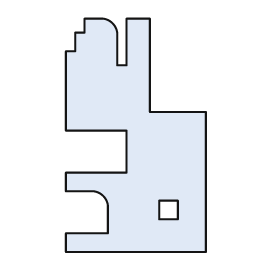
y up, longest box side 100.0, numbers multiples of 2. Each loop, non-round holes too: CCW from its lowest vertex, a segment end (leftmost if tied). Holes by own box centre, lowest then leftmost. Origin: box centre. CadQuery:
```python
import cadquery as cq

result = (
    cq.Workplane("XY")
    .moveTo(-30.0, -50.0)
    .lineTo(30.0, -50.0)
    .lineTo(30.0, 10.0)
    .lineTo(6.0, 10.0)
    .lineTo(6.0, 50.0)
    .lineTo(-4.0, 50.0)
    .lineTo(-4.0, 30.0)
    .lineTo(-8.0, 30.0)
    .lineTo(-8.0, 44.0)
    .threePointArc((-10.0, 48.0), (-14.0, 50.0))
    .lineTo(-22.0, 50.0)
    .lineTo(-22.0, 44.0)
    .lineTo(-26.0, 44.0)
    .lineTo(-26.0, 36.0)
    .lineTo(-30.0, 36.0)
    .lineTo(-30.0, 2.0)
    .lineTo(-4.0, 2.0)
    .lineTo(-4.0, -16.0)
    .lineTo(-30.0, -16.0)
    .lineTo(-30.0, -24.0)
    .lineTo(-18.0, -24.0)
    .threePointArc((-14.0, -26.0), (-12.0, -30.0))
    .lineTo(-12.0, -42.0)
    .lineTo(-30.0, -42.0)
    .close()
    .moveTo(10.0, -36.0)
    .lineTo(18.0, -36.0)
    .lineTo(18.0, -28.0)
    .lineTo(10.0, -28.0)
    .close()
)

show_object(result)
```